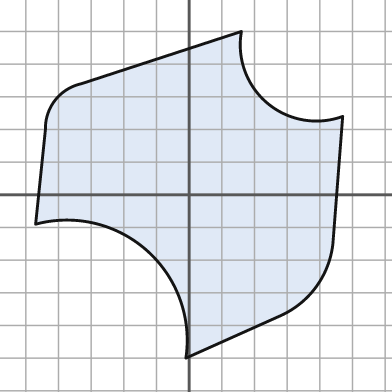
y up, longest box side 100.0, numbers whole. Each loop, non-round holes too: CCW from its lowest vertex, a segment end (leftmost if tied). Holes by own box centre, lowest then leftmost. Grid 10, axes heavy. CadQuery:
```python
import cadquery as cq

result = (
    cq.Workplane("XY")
    .moveTo(-1.0, -50.0)
    .lineTo(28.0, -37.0)
    .threePointArc((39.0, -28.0), (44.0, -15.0))
    .lineTo(47.0, 24.0)
    .threePointArc((24.0, 28.0), (16.0, 50.0))
    .lineTo(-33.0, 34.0)
    .threePointArc((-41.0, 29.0), (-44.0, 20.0))
    .lineTo(-47.0, -9.0)
    .threePointArc((-13.0, -17.0), (-1.0, -50.0))
    .close()
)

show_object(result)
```